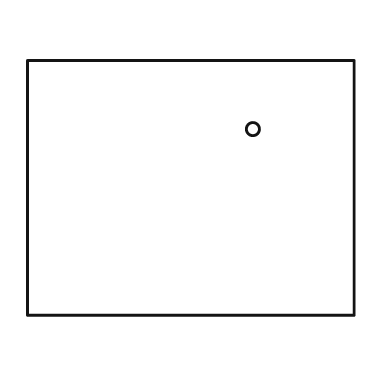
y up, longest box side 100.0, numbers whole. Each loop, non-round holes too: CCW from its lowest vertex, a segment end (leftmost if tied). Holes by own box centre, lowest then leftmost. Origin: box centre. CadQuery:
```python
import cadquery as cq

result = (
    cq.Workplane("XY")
    .moveTo(-50.0, -39.0)
    .lineTo(50.0, -39.0)
    .lineTo(50.0, 39.0)
    .lineTo(-50.0, 39.0)
    .close()
    .moveTo(19.0, 18.0)
    .circle(2.0)
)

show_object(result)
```